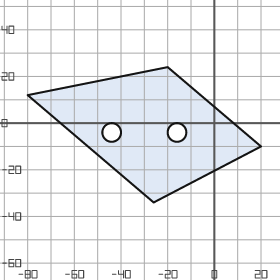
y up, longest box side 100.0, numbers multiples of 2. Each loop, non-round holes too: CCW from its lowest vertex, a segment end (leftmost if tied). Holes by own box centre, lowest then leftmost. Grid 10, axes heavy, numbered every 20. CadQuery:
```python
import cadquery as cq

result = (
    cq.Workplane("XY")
    .moveTo(-26.0, -34.0)
    .lineTo(20.0, -10.0)
    .lineTo(-20.0, 24.0)
    .lineTo(-80.0, 12.0)
    .close()
    .moveTo(-44.0, -4.0)
    .circle(4.0)
    .moveTo(-16.0, -4.0)
    .circle(4.0)
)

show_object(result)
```